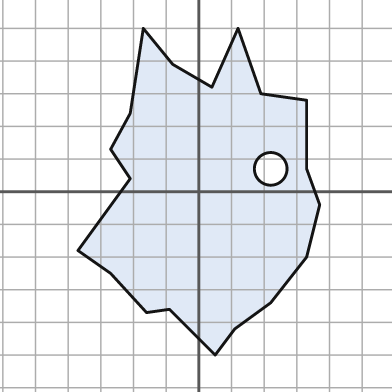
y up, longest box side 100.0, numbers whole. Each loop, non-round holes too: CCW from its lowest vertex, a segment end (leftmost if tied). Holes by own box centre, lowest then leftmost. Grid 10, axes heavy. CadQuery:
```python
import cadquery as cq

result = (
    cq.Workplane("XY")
    .moveTo(5.0, -50.0)
    .lineTo(11.0, -42.0)
    .lineTo(22.0, -34.0)
    .lineTo(33.0, -20.0)
    .lineTo(37.0, -4.0)
    .lineTo(33.0, 7.0)
    .lineTo(33.0, 28.0)
    .lineTo(19.0, 30.0)
    .lineTo(12.0, 50.0)
    .lineTo(4.0, 32.0)
    .lineTo(-8.0, 39.0)
    .lineTo(-17.0, 50.0)
    .lineTo(-21.0, 24.0)
    .lineTo(-27.0, 13.0)
    .lineTo(-21.0, 4.0)
    .lineTo(-37.0, -18.0)
    .lineTo(-27.0, -25.0)
    .lineTo(-16.0, -37.0)
    .lineTo(-9.0, -36.0)
    .close()
    .moveTo(22.0, 7.0)
    .circle(5.0)
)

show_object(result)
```